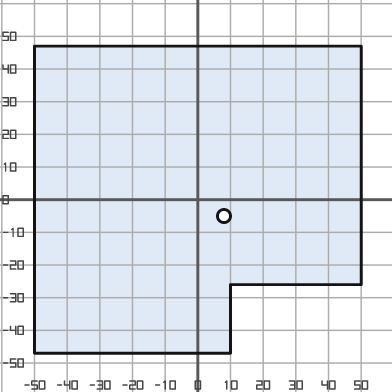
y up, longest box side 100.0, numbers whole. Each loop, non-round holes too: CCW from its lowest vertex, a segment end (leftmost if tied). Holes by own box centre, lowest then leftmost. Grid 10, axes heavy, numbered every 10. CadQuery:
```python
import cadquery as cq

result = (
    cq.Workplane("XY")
    .moveTo(-50.0, -47.0)
    .lineTo(10.0, -47.0)
    .lineTo(10.0, -26.0)
    .lineTo(50.0, -26.0)
    .lineTo(50.0, 47.0)
    .lineTo(-50.0, 47.0)
    .close()
    .moveTo(8.0, -5.0)
    .circle(2.0)
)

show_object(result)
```